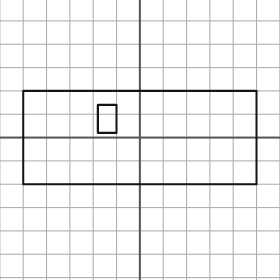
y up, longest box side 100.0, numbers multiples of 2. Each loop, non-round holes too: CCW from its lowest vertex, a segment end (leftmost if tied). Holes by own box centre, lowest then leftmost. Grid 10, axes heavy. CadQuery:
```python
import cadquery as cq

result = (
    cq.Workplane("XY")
    .moveTo(-50.0, -20.0)
    .lineTo(50.0, -20.0)
    .lineTo(50.0, 20.0)
    .lineTo(-50.0, 20.0)
    .close()
    .moveTo(-18.0, 2.0)
    .lineTo(-10.0, 2.0)
    .lineTo(-10.0, 14.0)
    .lineTo(-18.0, 14.0)
    .close()
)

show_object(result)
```